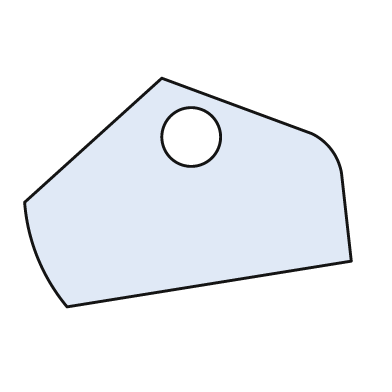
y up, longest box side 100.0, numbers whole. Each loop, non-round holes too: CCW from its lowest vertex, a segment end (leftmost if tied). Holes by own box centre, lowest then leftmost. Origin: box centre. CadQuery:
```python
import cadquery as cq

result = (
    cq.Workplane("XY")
    .moveTo(-37.0, -35.0)
    .lineTo(50.0, -21.0)
    .lineTo(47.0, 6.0)
    .threePointArc((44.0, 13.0), (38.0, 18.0))
    .lineTo(-8.0, 35.0)
    .lineTo(-50.0, -3.0)
    .threePointArc((-46.0, -20.0), (-37.0, -35.0))
    .close()
    .moveTo(1.0, 17.0)
    .circle(9.0)
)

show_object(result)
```